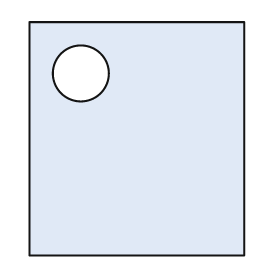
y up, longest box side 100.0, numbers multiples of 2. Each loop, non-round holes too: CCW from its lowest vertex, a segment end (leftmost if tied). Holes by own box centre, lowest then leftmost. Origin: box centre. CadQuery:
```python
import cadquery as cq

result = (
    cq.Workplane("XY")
    .moveTo(-46.0, -50.0)
    .lineTo(46.0, -50.0)
    .lineTo(46.0, 50.0)
    .lineTo(-46.0, 50.0)
    .close()
    .moveTo(-24.0, 28.0)
    .circle(12.0)
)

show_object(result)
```